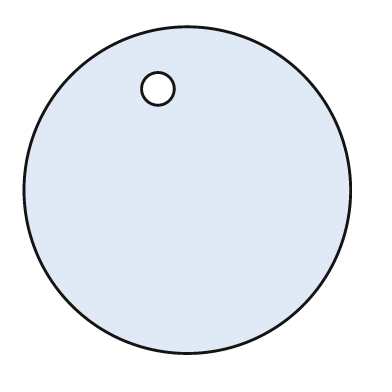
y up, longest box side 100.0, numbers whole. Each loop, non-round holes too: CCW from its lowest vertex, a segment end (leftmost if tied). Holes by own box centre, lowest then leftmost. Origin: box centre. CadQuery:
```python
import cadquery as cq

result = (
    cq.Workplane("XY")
    .moveTo(0.0, 0.0)
    .circle(50.0)
    .moveTo(-9.0, 31.0)
    .circle(5.0)
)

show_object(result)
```